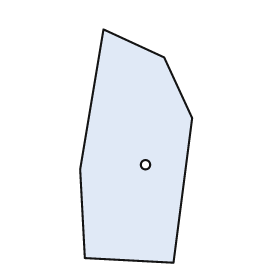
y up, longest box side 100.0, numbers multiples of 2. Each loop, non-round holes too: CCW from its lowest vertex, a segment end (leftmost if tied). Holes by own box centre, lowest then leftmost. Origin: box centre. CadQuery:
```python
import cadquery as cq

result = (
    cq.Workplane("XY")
    .moveTo(16.0, -50.0)
    .lineTo(24.0, 12.0)
    .lineTo(12.0, 38.0)
    .lineTo(-14.0, 50.0)
    .lineTo(-24.0, -10.0)
    .lineTo(-22.0, -48.0)
    .close()
    .moveTo(4.0, -8.0)
    .circle(2.0)
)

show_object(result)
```